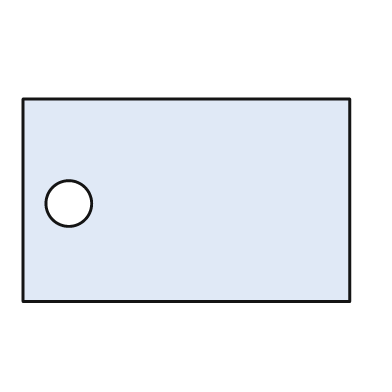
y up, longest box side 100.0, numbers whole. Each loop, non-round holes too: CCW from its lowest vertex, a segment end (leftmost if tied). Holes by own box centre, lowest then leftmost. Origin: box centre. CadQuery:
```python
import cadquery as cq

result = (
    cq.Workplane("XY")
    .moveTo(-50.0, -31.0)
    .lineTo(50.0, -31.0)
    .lineTo(50.0, 31.0)
    .lineTo(-50.0, 31.0)
    .close()
    .moveTo(-36.0, -1.0)
    .circle(7.0)
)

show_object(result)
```